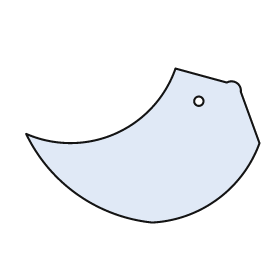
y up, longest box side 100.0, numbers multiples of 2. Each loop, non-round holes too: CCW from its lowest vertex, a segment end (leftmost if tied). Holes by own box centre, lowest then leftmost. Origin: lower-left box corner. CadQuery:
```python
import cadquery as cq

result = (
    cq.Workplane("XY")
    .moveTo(54.0, 0.0)
    .threePointArc((82.0, 10.0), (100.0, 34.0))
    .lineTo(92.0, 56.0)
    .threePointArc((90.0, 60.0), (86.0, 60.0))
    .lineTo(64.0, 66.0)
    .threePointArc((38.0, 38.0), (0.0, 38.0))
    .threePointArc((22.0, 12.0), (54.0, 0.0))
    .close()
    .moveTo(74.0, 52.0)
    .circle(2.0)
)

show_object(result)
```